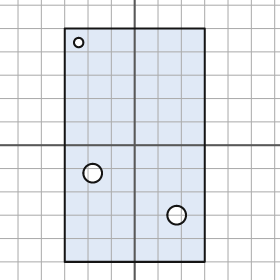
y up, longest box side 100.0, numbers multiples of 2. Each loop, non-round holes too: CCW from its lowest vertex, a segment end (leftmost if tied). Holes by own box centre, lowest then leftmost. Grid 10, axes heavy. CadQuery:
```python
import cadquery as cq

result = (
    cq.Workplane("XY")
    .moveTo(-30.0, -50.0)
    .lineTo(30.0, -50.0)
    .lineTo(30.0, 50.0)
    .lineTo(-30.0, 50.0)
    .close()
    .moveTo(18.0, -30.0)
    .circle(4.0)
    .moveTo(-18.0, -12.0)
    .circle(4.0)
    .moveTo(-24.0, 44.0)
    .circle(2.0)
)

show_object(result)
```